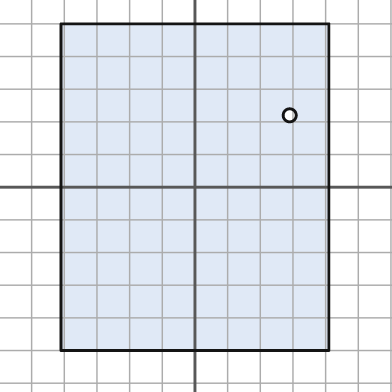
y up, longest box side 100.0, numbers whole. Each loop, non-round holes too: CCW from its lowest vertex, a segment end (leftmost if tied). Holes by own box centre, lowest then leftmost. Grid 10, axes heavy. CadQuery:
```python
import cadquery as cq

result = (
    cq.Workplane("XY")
    .moveTo(-41.0, -50.0)
    .lineTo(41.0, -50.0)
    .lineTo(41.0, 50.0)
    .lineTo(-41.0, 50.0)
    .close()
    .moveTo(29.0, 22.0)
    .circle(2.0)
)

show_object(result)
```